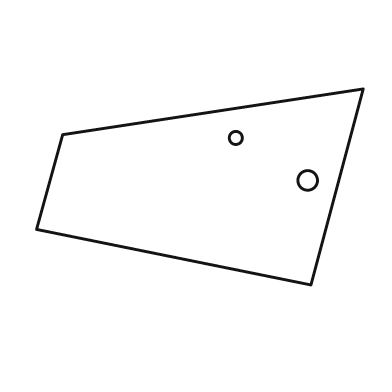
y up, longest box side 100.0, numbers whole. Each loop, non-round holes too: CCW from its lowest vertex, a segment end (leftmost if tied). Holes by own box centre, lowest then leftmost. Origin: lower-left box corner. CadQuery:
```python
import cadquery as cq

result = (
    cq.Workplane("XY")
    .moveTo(84.0, 0.0)
    .lineTo(100.0, 60.0)
    .lineTo(8.0, 46.0)
    .lineTo(0.0, 17.0)
    .close()
    .moveTo(83.0, 32.0)
    .circle(3.0)
    .moveTo(61.0, 45.0)
    .circle(2.0)
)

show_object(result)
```